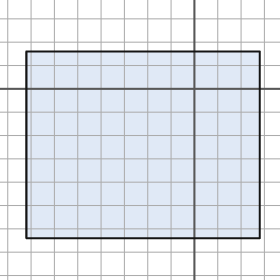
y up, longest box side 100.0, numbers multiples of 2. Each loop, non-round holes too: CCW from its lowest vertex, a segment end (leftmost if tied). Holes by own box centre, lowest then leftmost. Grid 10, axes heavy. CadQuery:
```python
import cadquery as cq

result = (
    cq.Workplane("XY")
    .moveTo(-72.0, -64.0)
    .lineTo(28.0, -64.0)
    .lineTo(28.0, 16.0)
    .lineTo(-72.0, 16.0)
    .close()
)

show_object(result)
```